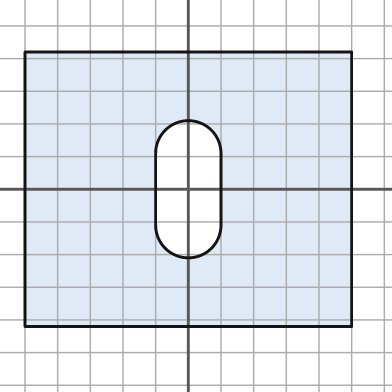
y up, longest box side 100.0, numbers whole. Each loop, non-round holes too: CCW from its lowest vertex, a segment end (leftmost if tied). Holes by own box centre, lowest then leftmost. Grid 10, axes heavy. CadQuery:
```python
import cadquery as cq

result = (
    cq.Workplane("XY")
    .moveTo(-50.0, -42.0)
    .lineTo(50.0, -42.0)
    .lineTo(50.0, 42.0)
    .lineTo(-50.0, 42.0)
    .close()
    .moveTo(-10.0, -11.0)
    .threePointArc((0.0, -21.0), (10.0, -11.0))
    .lineTo(10.0, 11.0)
    .threePointArc((0.0, 21.0), (-10.0, 11.0))
    .close()
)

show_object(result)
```